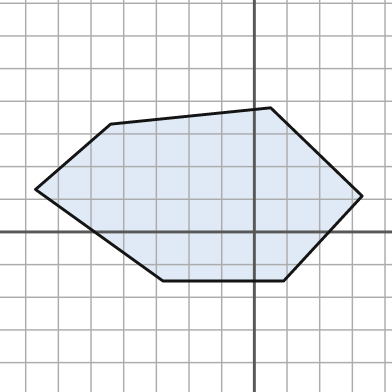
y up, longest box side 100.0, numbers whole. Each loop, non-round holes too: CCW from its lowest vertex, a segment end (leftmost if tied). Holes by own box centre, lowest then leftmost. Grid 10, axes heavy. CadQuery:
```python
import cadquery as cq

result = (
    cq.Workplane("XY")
    .moveTo(-28.0, -15.0)
    .lineTo(9.0, -15.0)
    .lineTo(33.0, 11.0)
    .lineTo(5.0, 38.0)
    .lineTo(-44.0, 33.0)
    .lineTo(-67.0, 13.0)
    .close()
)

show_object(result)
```